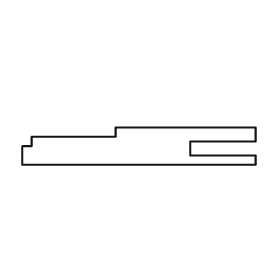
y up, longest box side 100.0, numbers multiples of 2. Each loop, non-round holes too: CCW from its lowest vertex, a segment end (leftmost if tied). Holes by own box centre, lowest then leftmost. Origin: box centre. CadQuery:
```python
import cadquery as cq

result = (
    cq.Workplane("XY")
    .moveTo(-50.0, -8.0)
    .lineTo(50.0, -8.0)
    .lineTo(50.0, -4.0)
    .lineTo(22.0, -4.0)
    .lineTo(22.0, 2.0)
    .lineTo(50.0, 2.0)
    .lineTo(50.0, 8.0)
    .lineTo(-10.0, 8.0)
    .lineTo(-10.0, 4.0)
    .lineTo(-46.0, 4.0)
    .lineTo(-46.0, 0.0)
    .lineTo(-50.0, 0.0)
    .close()
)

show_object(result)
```